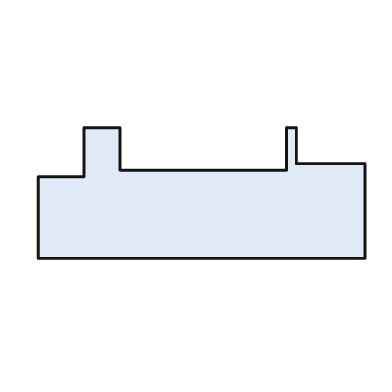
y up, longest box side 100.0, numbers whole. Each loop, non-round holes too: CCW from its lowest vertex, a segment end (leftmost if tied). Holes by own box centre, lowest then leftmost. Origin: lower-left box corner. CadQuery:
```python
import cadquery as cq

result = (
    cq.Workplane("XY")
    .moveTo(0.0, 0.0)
    .lineTo(100.0, 0.0)
    .lineTo(100.0, 29.0)
    .lineTo(79.0, 29.0)
    .lineTo(79.0, 40.0)
    .lineTo(76.0, 40.0)
    .lineTo(76.0, 27.0)
    .lineTo(25.0, 27.0)
    .lineTo(25.0, 40.0)
    .lineTo(14.0, 40.0)
    .lineTo(14.0, 25.0)
    .lineTo(0.0, 25.0)
    .close()
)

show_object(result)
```